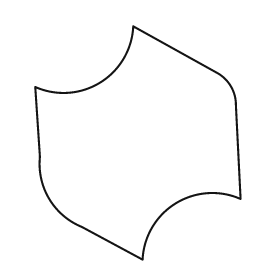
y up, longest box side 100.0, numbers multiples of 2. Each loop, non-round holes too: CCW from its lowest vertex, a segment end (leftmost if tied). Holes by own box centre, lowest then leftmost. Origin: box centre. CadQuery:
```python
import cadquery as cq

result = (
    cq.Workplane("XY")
    .moveTo(2.0, -50.0)
    .threePointArc((16.0, -26.0), (44.0, -24.0))
    .lineTo(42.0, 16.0)
    .threePointArc((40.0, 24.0), (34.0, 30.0))
    .lineTo(-2.0, 50.0)
    .threePointArc((-16.0, 26.0), (-44.0, 24.0))
    .lineTo(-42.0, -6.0)
    .threePointArc((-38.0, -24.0), (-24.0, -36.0))
    .close()
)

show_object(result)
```